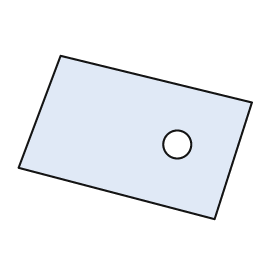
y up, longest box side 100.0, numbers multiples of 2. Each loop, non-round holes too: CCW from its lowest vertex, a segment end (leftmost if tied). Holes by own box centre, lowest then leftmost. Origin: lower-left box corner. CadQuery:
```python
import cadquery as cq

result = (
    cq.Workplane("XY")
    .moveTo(84.0, 0.0)
    .lineTo(100.0, 50.0)
    .lineTo(18.0, 70.0)
    .lineTo(0.0, 22.0)
    .close()
    .moveTo(68.0, 32.0)
    .circle(6.0)
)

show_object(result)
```